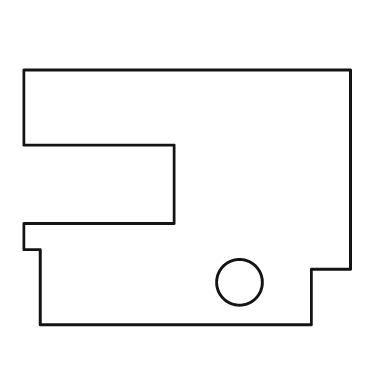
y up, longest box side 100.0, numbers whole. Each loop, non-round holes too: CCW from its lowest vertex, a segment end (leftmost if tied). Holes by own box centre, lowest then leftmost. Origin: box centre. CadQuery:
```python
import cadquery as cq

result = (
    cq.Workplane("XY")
    .moveTo(-45.0, -39.0)
    .lineTo(38.0, -39.0)
    .lineTo(38.0, -22.0)
    .lineTo(50.0, -22.0)
    .lineTo(50.0, 39.0)
    .lineTo(-50.0, 39.0)
    .lineTo(-50.0, 16.0)
    .lineTo(-4.0, 16.0)
    .lineTo(-4.0, -8.0)
    .lineTo(-50.0, -8.0)
    .lineTo(-50.0, -16.0)
    .lineTo(-45.0, -16.0)
    .close()
    .moveTo(16.0, -26.0)
    .circle(7.0)
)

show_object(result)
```